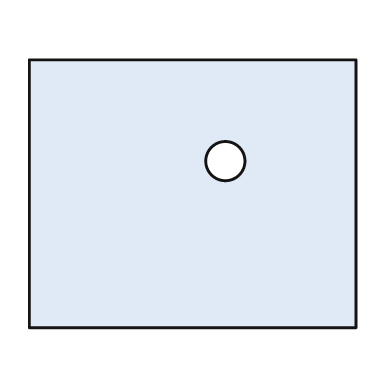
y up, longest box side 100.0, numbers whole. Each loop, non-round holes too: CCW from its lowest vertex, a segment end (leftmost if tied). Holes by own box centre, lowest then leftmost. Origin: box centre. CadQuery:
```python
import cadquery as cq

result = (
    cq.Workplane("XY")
    .moveTo(-50.0, -41.0)
    .lineTo(50.0, -41.0)
    .lineTo(50.0, 41.0)
    .lineTo(-50.0, 41.0)
    .close()
    .moveTo(10.0, 10.0)
    .circle(6.0)
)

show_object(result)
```